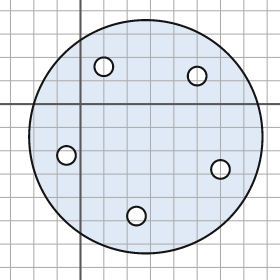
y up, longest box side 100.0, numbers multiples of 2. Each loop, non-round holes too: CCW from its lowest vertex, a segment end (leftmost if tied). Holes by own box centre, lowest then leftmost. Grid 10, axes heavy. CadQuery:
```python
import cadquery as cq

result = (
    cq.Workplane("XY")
    .moveTo(28.0, -14.0)
    .circle(50.0)
    .moveTo(24.0, -48.0)
    .circle(4.0)
    .moveTo(60.0, -28.0)
    .circle(4.0)
    .moveTo(-6.0, -22.0)
    .circle(4.0)
    .moveTo(50.0, 12.0)
    .circle(4.0)
    .moveTo(10.0, 16.0)
    .circle(4.0)
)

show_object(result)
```